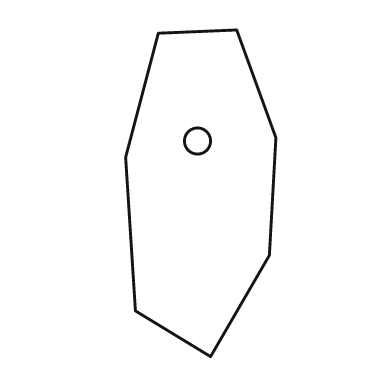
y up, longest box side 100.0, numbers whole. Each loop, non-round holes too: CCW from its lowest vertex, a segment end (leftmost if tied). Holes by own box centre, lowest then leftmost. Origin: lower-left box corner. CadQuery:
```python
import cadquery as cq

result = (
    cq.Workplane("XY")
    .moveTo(26.0, 0.0)
    .lineTo(44.0, 31.0)
    .lineTo(46.0, 67.0)
    .lineTo(34.0, 100.0)
    .lineTo(10.0, 99.0)
    .lineTo(0.0, 61.0)
    .lineTo(3.0, 14.0)
    .close()
    .moveTo(22.0, 66.0)
    .circle(4.0)
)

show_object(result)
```